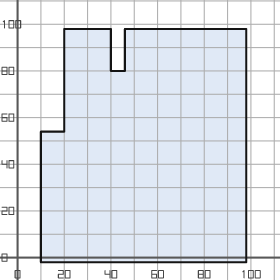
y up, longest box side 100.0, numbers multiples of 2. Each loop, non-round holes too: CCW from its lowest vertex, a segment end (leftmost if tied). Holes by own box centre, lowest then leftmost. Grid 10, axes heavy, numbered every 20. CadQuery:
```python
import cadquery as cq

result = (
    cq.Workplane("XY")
    .moveTo(10.0, -2.0)
    .lineTo(98.0, -2.0)
    .lineTo(98.0, 98.0)
    .lineTo(46.0, 98.0)
    .lineTo(46.0, 80.0)
    .lineTo(40.0, 80.0)
    .lineTo(40.0, 98.0)
    .lineTo(20.0, 98.0)
    .lineTo(20.0, 54.0)
    .lineTo(10.0, 54.0)
    .close()
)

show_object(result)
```